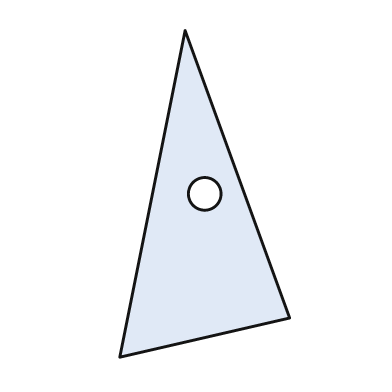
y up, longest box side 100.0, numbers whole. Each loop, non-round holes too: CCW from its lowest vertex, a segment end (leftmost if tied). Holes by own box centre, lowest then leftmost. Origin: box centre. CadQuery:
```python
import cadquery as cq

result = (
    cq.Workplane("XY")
    .moveTo(-26.0, -50.0)
    .lineTo(26.0, -38.0)
    .lineTo(-6.0, 50.0)
    .close()
    .moveTo(0.0, 0.0)
    .circle(5.0)
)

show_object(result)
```